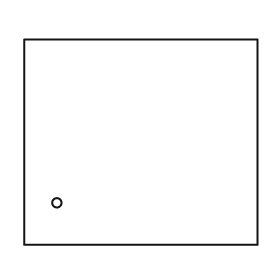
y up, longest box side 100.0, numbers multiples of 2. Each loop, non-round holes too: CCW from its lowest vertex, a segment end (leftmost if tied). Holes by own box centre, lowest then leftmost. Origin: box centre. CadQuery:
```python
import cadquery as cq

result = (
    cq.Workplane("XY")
    .moveTo(-50.0, -44.0)
    .lineTo(50.0, -44.0)
    .lineTo(50.0, 44.0)
    .lineTo(-50.0, 44.0)
    .close()
    .moveTo(-36.0, -26.0)
    .circle(2.0)
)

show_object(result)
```